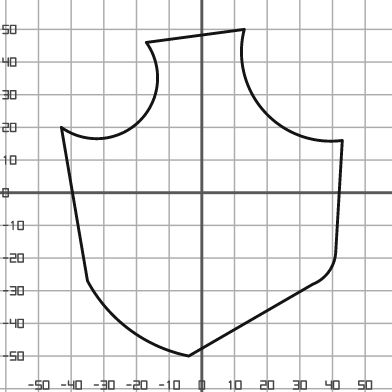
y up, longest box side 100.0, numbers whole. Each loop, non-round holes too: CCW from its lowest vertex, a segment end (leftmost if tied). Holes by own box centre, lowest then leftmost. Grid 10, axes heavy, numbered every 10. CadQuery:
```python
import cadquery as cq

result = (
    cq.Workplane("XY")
    .moveTo(-4.0, -50.0)
    .lineTo(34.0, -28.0)
    .threePointArc((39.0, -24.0), (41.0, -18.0))
    .lineTo(43.0, 16.0)
    .threePointArc((19.0, 25.0), (13.0, 50.0))
    .lineTo(-17.0, 46.0)
    .threePointArc((-19.0, 22.0), (-43.0, 20.0))
    .lineTo(-35.0, -27.0)
    .threePointArc((-22.0, -42.0), (-4.0, -50.0))
    .close()
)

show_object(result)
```